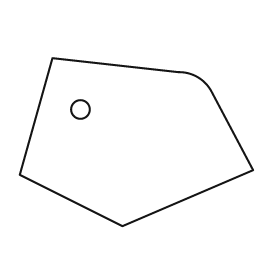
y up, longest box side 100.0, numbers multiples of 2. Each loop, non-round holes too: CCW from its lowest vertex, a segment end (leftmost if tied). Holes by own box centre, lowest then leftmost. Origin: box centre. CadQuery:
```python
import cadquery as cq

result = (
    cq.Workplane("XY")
    .moveTo(-6.0, -36.0)
    .lineTo(50.0, -12.0)
    .lineTo(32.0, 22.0)
    .threePointArc((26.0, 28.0), (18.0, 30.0))
    .lineTo(-36.0, 36.0)
    .lineTo(-50.0, -14.0)
    .close()
    .moveTo(-24.0, 14.0)
    .circle(4.0)
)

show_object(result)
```